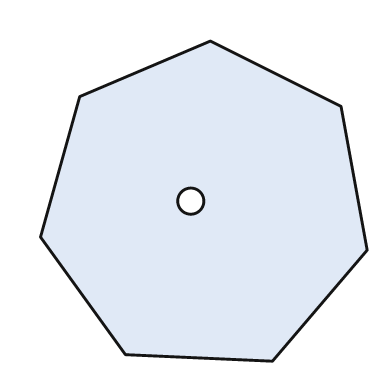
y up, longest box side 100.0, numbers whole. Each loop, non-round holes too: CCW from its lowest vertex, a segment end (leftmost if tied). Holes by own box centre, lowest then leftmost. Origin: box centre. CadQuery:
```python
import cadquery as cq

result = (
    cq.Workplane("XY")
    .moveTo(21.0, -49.0)
    .lineTo(50.0, -15.0)
    .lineTo(42.0, 29.0)
    .lineTo(2.0, 49.0)
    .lineTo(-38.0, 32.0)
    .lineTo(-50.0, -11.0)
    .lineTo(-24.0, -47.0)
    .close()
    .moveTo(-4.0, 0.0)
    .circle(4.0)
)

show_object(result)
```